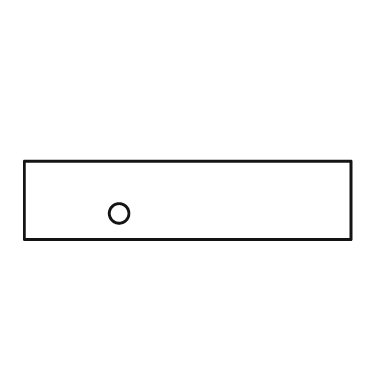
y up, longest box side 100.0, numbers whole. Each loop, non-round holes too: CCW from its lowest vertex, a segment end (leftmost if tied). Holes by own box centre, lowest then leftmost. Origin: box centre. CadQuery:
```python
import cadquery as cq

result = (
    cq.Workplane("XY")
    .moveTo(-50.0, -12.0)
    .lineTo(50.0, -12.0)
    .lineTo(50.0, 12.0)
    .lineTo(-50.0, 12.0)
    .close()
    .moveTo(-21.0, -4.0)
    .circle(3.0)
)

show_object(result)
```